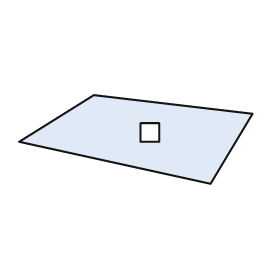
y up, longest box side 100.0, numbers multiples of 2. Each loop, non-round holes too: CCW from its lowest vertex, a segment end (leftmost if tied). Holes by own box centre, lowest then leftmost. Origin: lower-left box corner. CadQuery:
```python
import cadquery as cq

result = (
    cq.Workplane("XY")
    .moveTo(82.0, 0.0)
    .lineTo(100.0, 30.0)
    .lineTo(32.0, 38.0)
    .lineTo(0.0, 18.0)
    .close()
    .moveTo(52.0, 18.0)
    .lineTo(60.0, 18.0)
    .lineTo(60.0, 26.0)
    .lineTo(52.0, 26.0)
    .close()
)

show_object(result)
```